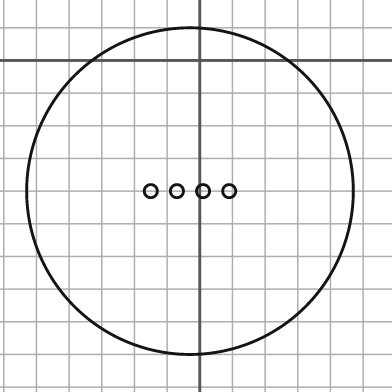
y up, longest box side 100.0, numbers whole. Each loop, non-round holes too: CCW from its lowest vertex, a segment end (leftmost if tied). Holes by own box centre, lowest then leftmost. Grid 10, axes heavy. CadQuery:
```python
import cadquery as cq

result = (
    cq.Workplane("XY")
    .moveTo(-3.0, -40.0)
    .circle(50.0)
    .moveTo(-15.0, -40.0)
    .circle(2.0)
    .moveTo(-7.0, -40.0)
    .circle(2.0)
    .moveTo(1.0, -40.0)
    .circle(2.0)
    .moveTo(9.0, -40.0)
    .circle(2.0)
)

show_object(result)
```